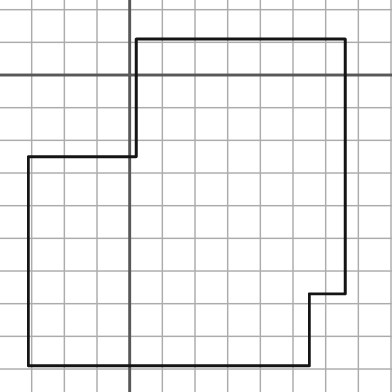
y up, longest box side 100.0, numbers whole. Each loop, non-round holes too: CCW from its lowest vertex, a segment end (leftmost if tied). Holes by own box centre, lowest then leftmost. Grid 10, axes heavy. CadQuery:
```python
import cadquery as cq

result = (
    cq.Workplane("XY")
    .moveTo(-31.0, -89.0)
    .lineTo(55.0, -89.0)
    .lineTo(55.0, -67.0)
    .lineTo(66.0, -67.0)
    .lineTo(66.0, 11.0)
    .lineTo(2.0, 11.0)
    .lineTo(2.0, -25.0)
    .lineTo(-31.0, -25.0)
    .close()
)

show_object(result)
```